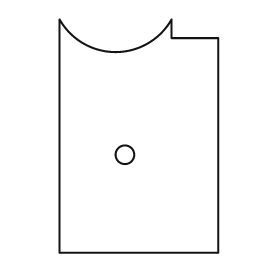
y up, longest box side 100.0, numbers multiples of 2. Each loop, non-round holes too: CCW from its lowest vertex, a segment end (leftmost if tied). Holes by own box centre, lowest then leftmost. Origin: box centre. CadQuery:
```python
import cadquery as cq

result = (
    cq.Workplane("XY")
    .moveTo(-34.0, -50.0)
    .lineTo(34.0, -50.0)
    .lineTo(34.0, 42.0)
    .lineTo(14.0, 42.0)
    .lineTo(14.0, 50.0)
    .threePointArc((-10.0, 36.0), (-34.0, 50.0))
    .close()
    .moveTo(-6.0, -8.0)
    .circle(4.0)
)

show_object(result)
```